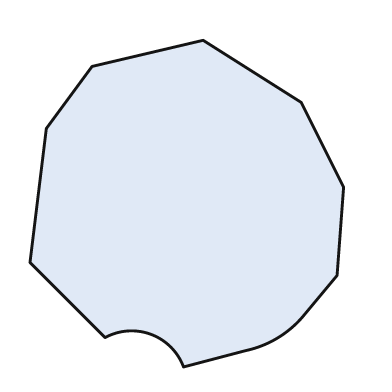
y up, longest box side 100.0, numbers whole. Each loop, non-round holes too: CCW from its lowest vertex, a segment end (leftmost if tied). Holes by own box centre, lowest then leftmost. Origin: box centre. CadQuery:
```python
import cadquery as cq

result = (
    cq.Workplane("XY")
    .moveTo(-1.0, -50.0)
    .lineTo(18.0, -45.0)
    .threePointArc((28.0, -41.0), (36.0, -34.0))
    .lineTo(46.0, -22.0)
    .lineTo(48.0, 5.0)
    .lineTo(35.0, 31.0)
    .lineTo(5.0, 50.0)
    .lineTo(-29.0, 42.0)
    .lineTo(-43.0, 23.0)
    .lineTo(-48.0, -18.0)
    .lineTo(-25.0, -41.0)
    .threePointArc((-11.0, -40.0), (-1.0, -50.0))
    .close()
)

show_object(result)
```